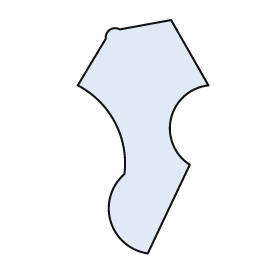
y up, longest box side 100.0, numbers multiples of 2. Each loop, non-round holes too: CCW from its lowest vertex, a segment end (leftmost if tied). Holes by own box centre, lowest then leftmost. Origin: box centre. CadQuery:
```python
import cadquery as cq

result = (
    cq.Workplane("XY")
    .moveTo(2.0, -50.0)
    .lineTo(20.0, -12.0)
    .threePointArc((12.0, 8.0), (28.0, 22.0))
    .lineTo(12.0, 50.0)
    .lineTo(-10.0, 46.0)
    .threePointArc((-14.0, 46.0), (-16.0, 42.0))
    .lineTo(-28.0, 22.0)
    .threePointArc((-12.0, 6.0), (-8.0, -16.0))
    .threePointArc((-14.0, -36.0), (2.0, -50.0))
    .close()
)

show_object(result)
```